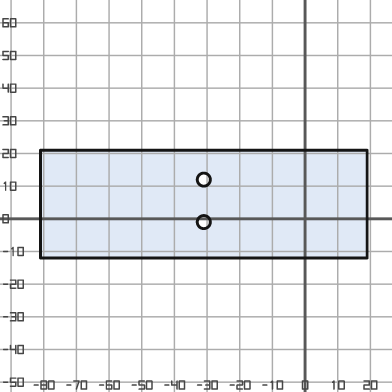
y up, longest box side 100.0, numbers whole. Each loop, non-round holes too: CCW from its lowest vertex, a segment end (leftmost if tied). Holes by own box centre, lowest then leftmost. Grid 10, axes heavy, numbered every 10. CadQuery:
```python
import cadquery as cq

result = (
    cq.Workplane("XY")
    .moveTo(-81.0, -12.0)
    .lineTo(19.0, -12.0)
    .lineTo(19.0, 21.0)
    .lineTo(-81.0, 21.0)
    .close()
    .moveTo(-31.0, -1.0)
    .circle(2.0)
    .moveTo(-31.0, 12.0)
    .circle(2.0)
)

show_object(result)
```